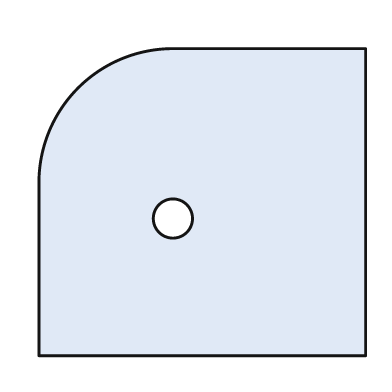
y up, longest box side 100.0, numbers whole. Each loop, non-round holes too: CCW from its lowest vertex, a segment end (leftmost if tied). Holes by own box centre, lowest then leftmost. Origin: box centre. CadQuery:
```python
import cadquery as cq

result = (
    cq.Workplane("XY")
    .moveTo(-50.0, -47.0)
    .lineTo(50.0, -47.0)
    .lineTo(50.0, 47.0)
    .lineTo(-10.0, 47.0)
    .threePointArc((-38.0, 35.0), (-50.0, 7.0))
    .close()
    .moveTo(-9.0, -5.0)
    .circle(6.0)
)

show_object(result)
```